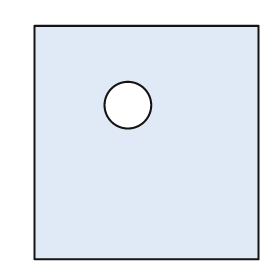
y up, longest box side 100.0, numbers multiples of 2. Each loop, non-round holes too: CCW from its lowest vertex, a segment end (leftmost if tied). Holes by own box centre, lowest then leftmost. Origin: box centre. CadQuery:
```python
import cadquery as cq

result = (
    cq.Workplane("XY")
    .moveTo(-48.0, -50.0)
    .lineTo(48.0, -50.0)
    .lineTo(48.0, 50.0)
    .lineTo(-48.0, 50.0)
    .close()
    .moveTo(-8.0, 16.0)
    .circle(10.0)
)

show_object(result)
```